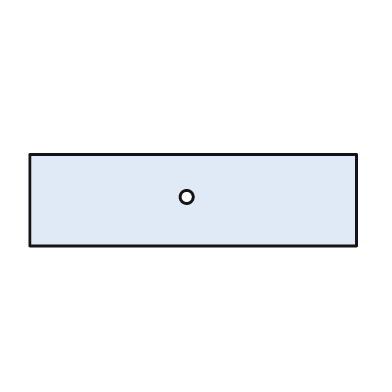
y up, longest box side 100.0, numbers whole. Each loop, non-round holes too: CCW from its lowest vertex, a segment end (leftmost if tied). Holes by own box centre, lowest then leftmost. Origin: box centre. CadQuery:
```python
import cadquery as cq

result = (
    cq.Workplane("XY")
    .moveTo(-50.0, -14.0)
    .lineTo(50.0, -14.0)
    .lineTo(50.0, 14.0)
    .lineTo(-50.0, 14.0)
    .close()
    .moveTo(-2.0, 1.0)
    .circle(2.0)
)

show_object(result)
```